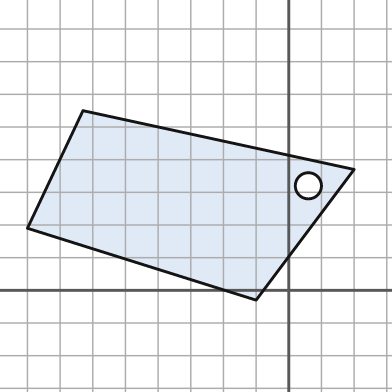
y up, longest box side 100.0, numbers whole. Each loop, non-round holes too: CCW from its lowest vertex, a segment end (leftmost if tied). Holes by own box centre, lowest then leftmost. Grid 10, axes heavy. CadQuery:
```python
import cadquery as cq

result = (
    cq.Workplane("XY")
    .moveTo(-10.0, -3.0)
    .lineTo(20.0, 37.0)
    .lineTo(-63.0, 55.0)
    .lineTo(-80.0, 19.0)
    .close()
    .moveTo(6.0, 32.0)
    .circle(4.0)
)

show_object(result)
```